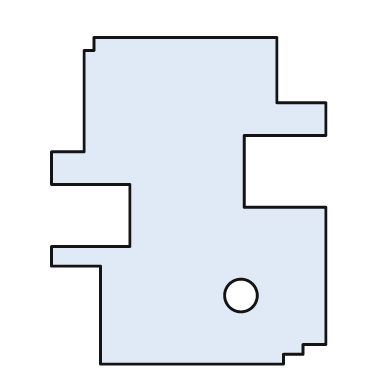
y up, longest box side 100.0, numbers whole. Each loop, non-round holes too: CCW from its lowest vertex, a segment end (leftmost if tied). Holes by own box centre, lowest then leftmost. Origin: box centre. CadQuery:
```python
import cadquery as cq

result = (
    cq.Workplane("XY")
    .moveTo(-27.0, -50.0)
    .lineTo(29.0, -50.0)
    .lineTo(29.0, -47.0)
    .lineTo(35.0, -47.0)
    .lineTo(35.0, -44.0)
    .lineTo(42.0, -44.0)
    .lineTo(42.0, -2.0)
    .lineTo(17.0, -2.0)
    .lineTo(17.0, 20.0)
    .lineTo(42.0, 20.0)
    .lineTo(42.0, 30.0)
    .lineTo(27.0, 30.0)
    .lineTo(27.0, 50.0)
    .lineTo(-29.0, 50.0)
    .lineTo(-29.0, 46.0)
    .lineTo(-32.0, 46.0)
    .lineTo(-32.0, 15.0)
    .lineTo(-42.0, 15.0)
    .lineTo(-42.0, 5.0)
    .lineTo(-18.0, 5.0)
    .lineTo(-18.0, -14.0)
    .lineTo(-42.0, -14.0)
    .lineTo(-42.0, -20.0)
    .lineTo(-27.0, -20.0)
    .close()
    .moveTo(16.0, -29.0)
    .circle(5.0)
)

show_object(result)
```